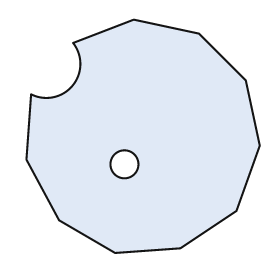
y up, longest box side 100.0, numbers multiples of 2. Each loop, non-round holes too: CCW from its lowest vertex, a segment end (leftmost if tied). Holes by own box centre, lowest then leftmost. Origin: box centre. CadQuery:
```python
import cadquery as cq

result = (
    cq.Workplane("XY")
    .moveTo(-12.0, -50.0)
    .lineTo(16.0, -48.0)
    .lineTo(40.0, -32.0)
    .lineTo(50.0, -4.0)
    .lineTo(44.0, 24.0)
    .lineTo(24.0, 44.0)
    .lineTo(-4.0, 50.0)
    .lineTo(-30.0, 40.0)
    .threePointArc((-30.0, 22.0), (-48.0, 18.0))
    .lineTo(-50.0, -10.0)
    .lineTo(-36.0, -36.0)
    .close()
    .moveTo(-8.0, -12.0)
    .circle(6.0)
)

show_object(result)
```